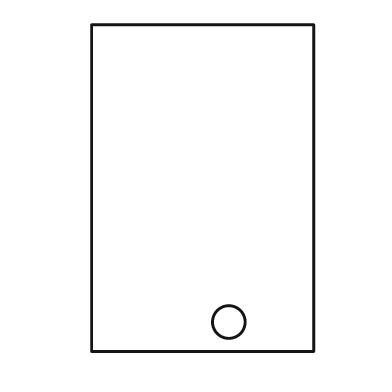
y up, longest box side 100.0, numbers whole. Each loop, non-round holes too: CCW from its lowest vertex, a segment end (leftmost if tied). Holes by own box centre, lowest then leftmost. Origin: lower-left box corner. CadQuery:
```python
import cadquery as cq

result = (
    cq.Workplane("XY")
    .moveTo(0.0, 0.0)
    .lineTo(68.0, 0.0)
    .lineTo(68.0, 100.0)
    .lineTo(0.0, 100.0)
    .close()
    .moveTo(42.0, 9.0)
    .circle(5.0)
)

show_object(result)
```